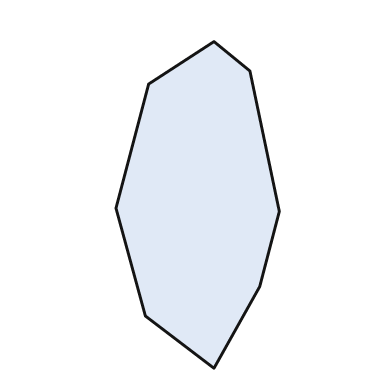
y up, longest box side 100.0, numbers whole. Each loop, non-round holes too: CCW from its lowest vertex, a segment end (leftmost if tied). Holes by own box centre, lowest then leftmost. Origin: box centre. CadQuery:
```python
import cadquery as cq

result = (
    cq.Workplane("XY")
    .moveTo(5.0, -50.0)
    .lineTo(19.0, -25.0)
    .lineTo(25.0, -2.0)
    .lineTo(16.0, 41.0)
    .lineTo(5.0, 50.0)
    .lineTo(-15.0, 37.0)
    .lineTo(-25.0, -1.0)
    .lineTo(-16.0, -34.0)
    .close()
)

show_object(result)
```